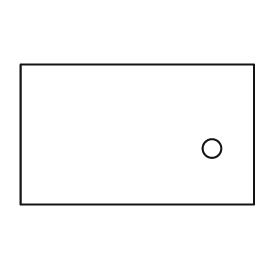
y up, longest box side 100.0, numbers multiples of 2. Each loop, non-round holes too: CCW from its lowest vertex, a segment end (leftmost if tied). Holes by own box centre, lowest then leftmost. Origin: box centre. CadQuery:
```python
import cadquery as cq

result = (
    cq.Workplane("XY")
    .moveTo(-50.0, -30.0)
    .lineTo(50.0, -30.0)
    .lineTo(50.0, 30.0)
    .lineTo(-50.0, 30.0)
    .close()
    .moveTo(32.0, -6.0)
    .circle(4.0)
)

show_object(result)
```